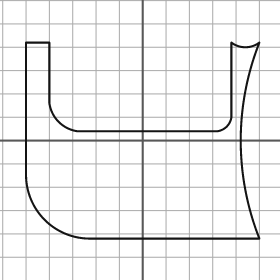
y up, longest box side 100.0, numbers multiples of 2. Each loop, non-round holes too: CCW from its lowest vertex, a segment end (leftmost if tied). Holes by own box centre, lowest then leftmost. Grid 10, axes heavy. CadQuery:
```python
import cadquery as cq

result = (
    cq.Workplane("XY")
    .moveTo(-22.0, -42.0)
    .lineTo(50.0, -42.0)
    .threePointArc((42.0, 0.0), (50.0, 42.0))
    .threePointArc((44.0, 40.0), (38.0, 42.0))
    .lineTo(38.0, 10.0)
    .threePointArc((36.0, 6.0), (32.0, 4.0))
    .lineTo(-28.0, 4.0)
    .threePointArc((-36.0, 8.0), (-40.0, 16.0))
    .lineTo(-40.0, 42.0)
    .lineTo(-50.0, 42.0)
    .lineTo(-50.0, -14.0)
    .threePointArc((-42.0, -34.0), (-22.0, -42.0))
    .close()
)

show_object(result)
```